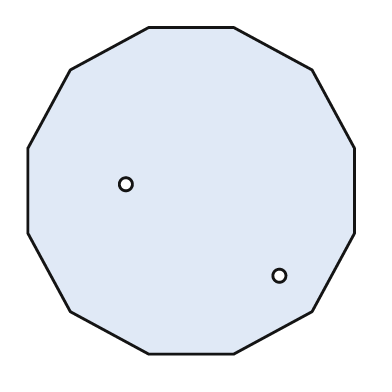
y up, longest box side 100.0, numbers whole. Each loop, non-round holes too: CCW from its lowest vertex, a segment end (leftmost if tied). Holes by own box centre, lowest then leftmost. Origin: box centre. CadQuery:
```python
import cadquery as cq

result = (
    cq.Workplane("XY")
    .moveTo(-13.0, -50.0)
    .lineTo(13.0, -50.0)
    .lineTo(37.0, -37.0)
    .lineTo(50.0, -13.0)
    .lineTo(50.0, 13.0)
    .lineTo(37.0, 37.0)
    .lineTo(13.0, 50.0)
    .lineTo(-13.0, 50.0)
    .lineTo(-37.0, 37.0)
    .lineTo(-50.0, 13.0)
    .lineTo(-50.0, -13.0)
    .lineTo(-37.0, -37.0)
    .close()
    .moveTo(27.0, -26.0)
    .circle(2.0)
    .moveTo(-20.0, 2.0)
    .circle(2.0)
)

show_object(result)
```